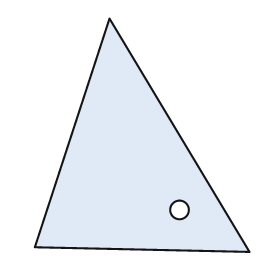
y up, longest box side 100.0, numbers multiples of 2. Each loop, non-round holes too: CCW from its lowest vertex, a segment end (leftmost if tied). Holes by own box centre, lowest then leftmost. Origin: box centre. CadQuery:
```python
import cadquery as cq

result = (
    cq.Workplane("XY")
    .moveTo(46.0, -50.0)
    .lineTo(-14.0, 50.0)
    .lineTo(-46.0, -48.0)
    .close()
    .moveTo(16.0, -32.0)
    .circle(4.0)
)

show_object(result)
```